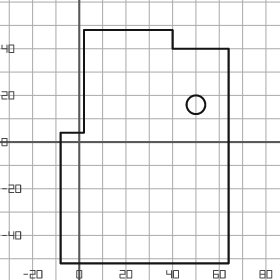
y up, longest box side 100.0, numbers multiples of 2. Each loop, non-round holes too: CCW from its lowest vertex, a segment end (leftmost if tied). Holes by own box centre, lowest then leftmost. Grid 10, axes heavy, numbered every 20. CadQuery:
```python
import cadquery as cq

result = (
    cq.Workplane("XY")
    .moveTo(-8.0, -52.0)
    .lineTo(64.0, -52.0)
    .lineTo(64.0, 40.0)
    .lineTo(40.0, 40.0)
    .lineTo(40.0, 48.0)
    .lineTo(2.0, 48.0)
    .lineTo(2.0, 4.0)
    .lineTo(-8.0, 4.0)
    .close()
    .moveTo(50.0, 16.0)
    .circle(4.0)
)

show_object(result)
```